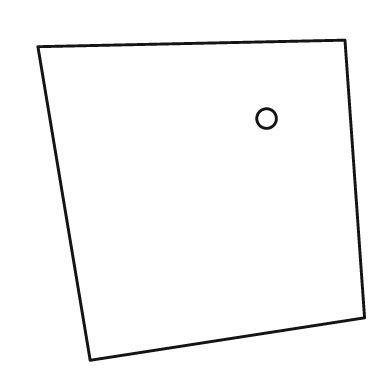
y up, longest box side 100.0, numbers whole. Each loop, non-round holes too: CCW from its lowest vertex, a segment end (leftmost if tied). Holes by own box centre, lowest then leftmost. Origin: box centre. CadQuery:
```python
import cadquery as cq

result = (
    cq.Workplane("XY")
    .moveTo(-34.0, -49.0)
    .lineTo(50.0, -36.0)
    .lineTo(44.0, 49.0)
    .lineTo(-50.0, 47.0)
    .close()
    .moveTo(20.0, 25.0)
    .circle(3.0)
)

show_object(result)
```